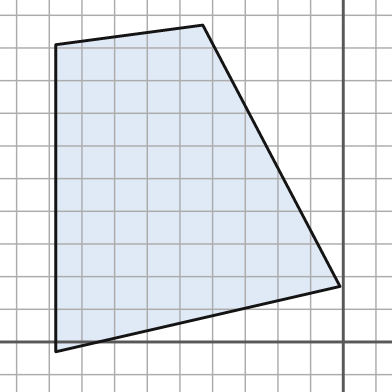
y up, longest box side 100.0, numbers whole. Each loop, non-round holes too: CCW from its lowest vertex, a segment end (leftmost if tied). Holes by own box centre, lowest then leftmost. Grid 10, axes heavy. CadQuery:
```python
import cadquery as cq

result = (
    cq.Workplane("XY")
    .moveTo(-88.0, -3.0)
    .lineTo(-1.0, 17.0)
    .lineTo(-43.0, 97.0)
    .lineTo(-88.0, 91.0)
    .close()
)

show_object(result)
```